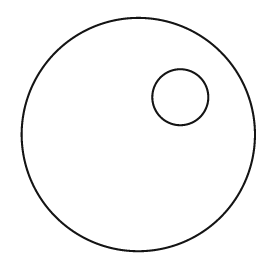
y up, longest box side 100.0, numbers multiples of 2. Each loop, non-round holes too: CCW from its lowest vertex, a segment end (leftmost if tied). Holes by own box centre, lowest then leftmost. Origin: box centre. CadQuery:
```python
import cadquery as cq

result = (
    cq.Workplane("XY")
    .moveTo(0.0, 0.0)
    .circle(50.0)
    .moveTo(18.0, 16.0)
    .circle(12.0)
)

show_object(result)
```